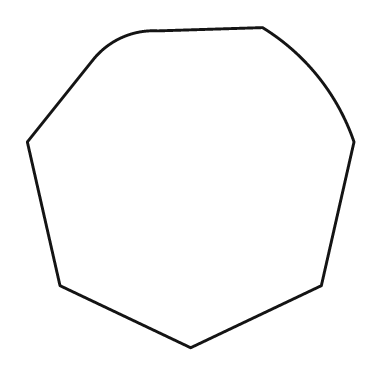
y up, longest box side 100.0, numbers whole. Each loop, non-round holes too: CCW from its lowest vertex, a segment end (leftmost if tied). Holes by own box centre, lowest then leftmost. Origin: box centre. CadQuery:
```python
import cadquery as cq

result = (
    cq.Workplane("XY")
    .moveTo(0.0, -49.0)
    .lineTo(40.0, -30.0)
    .lineTo(50.0, 14.0)
    .threePointArc((39.0, 34.0), (22.0, 49.0))
    .lineTo(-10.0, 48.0)
    .threePointArc((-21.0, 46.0), (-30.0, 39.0))
    .lineTo(-50.0, 14.0)
    .lineTo(-40.0, -30.0)
    .close()
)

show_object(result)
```